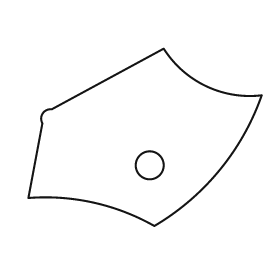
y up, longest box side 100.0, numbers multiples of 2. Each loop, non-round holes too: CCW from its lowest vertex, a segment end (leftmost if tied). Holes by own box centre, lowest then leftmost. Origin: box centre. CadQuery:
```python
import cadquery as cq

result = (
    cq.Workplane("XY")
    .moveTo(4.0, -38.0)
    .threePointArc((32.0, -14.0), (50.0, 18.0))
    .threePointArc((26.0, 22.0), (8.0, 38.0))
    .lineTo(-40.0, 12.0)
    .threePointArc((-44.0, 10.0), (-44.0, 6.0))
    .lineTo(-50.0, -26.0)
    .threePointArc((-22.0, -28.0), (4.0, -38.0))
    .close()
    .moveTo(2.0, -12.0)
    .circle(6.0)
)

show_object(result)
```